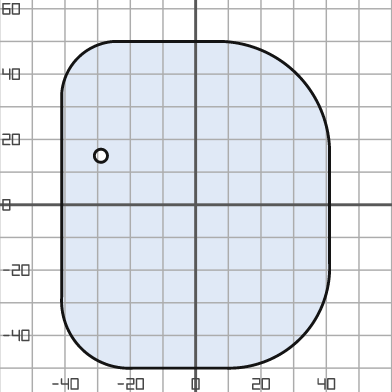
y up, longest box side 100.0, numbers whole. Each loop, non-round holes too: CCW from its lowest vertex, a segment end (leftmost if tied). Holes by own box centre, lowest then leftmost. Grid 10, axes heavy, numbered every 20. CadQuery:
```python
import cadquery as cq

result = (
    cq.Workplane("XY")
    .moveTo(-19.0, -50.0)
    .lineTo(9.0, -50.0)
    .threePointArc((32.0, -41.0), (41.0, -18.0))
    .lineTo(41.0, 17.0)
    .threePointArc((31.0, 40.0), (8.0, 50.0))
    .lineTo(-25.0, 50.0)
    .threePointArc((-36.0, 45.0), (-41.0, 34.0))
    .lineTo(-41.0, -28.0)
    .threePointArc((-35.0, -44.0), (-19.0, -50.0))
    .close()
    .moveTo(-29.0, 15.0)
    .circle(2.0)
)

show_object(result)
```